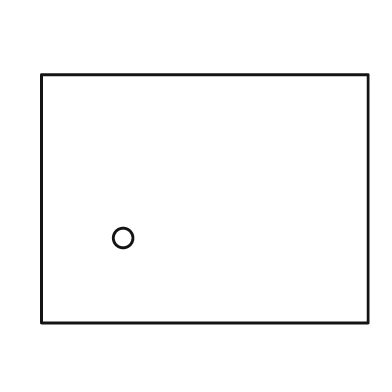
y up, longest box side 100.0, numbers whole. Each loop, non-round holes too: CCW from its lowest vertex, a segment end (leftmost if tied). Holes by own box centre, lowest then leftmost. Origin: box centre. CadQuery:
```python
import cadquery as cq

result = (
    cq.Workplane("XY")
    .moveTo(-50.0, -38.0)
    .lineTo(50.0, -38.0)
    .lineTo(50.0, 38.0)
    .lineTo(-50.0, 38.0)
    .close()
    .moveTo(-25.0, -12.0)
    .circle(3.0)
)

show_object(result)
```